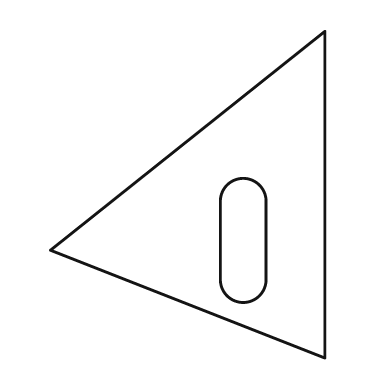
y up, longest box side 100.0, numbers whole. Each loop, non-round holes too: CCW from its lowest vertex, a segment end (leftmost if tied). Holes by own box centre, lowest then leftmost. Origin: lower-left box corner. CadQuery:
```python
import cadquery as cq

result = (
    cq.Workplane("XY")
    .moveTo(84.0, 0.0)
    .lineTo(84.0, 100.0)
    .lineTo(0.0, 33.0)
    .close()
    .moveTo(52.0, 24.0)
    .threePointArc((59.0, 17.0), (66.0, 24.0))
    .lineTo(66.0, 48.0)
    .threePointArc((59.0, 55.0), (52.0, 48.0))
    .close()
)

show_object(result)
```